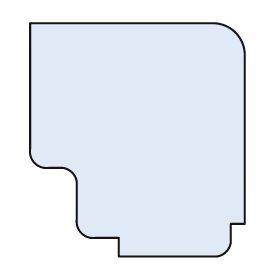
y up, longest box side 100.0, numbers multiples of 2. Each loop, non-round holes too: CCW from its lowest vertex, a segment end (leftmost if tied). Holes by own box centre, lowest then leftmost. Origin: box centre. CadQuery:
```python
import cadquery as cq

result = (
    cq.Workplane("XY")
    .moveTo(-8.0, -50.0)
    .lineTo(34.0, -50.0)
    .threePointArc((38.0, -48.0), (40.0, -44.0))
    .lineTo(40.0, -36.0)
    .lineTo(46.0, -36.0)
    .lineTo(46.0, 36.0)
    .threePointArc((42.0, 46.0), (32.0, 50.0))
    .lineTo(-46.0, 50.0)
    .lineTo(-46.0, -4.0)
    .threePointArc((-44.0, -10.0), (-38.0, -12.0))
    .lineTo(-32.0, -12.0)
    .threePointArc((-28.0, -14.0), (-26.0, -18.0))
    .lineTo(-26.0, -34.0)
    .threePointArc((-24.0, -40.0), (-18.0, -42.0))
    .lineTo(-8.0, -42.0)
    .close()
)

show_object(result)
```